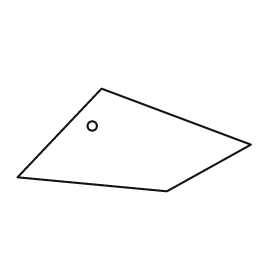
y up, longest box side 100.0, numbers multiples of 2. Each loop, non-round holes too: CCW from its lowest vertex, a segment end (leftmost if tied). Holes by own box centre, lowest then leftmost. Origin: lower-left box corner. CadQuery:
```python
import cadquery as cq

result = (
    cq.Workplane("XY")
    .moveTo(64.0, 0.0)
    .lineTo(100.0, 20.0)
    .lineTo(36.0, 44.0)
    .lineTo(0.0, 6.0)
    .close()
    .moveTo(32.0, 28.0)
    .circle(2.0)
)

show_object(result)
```